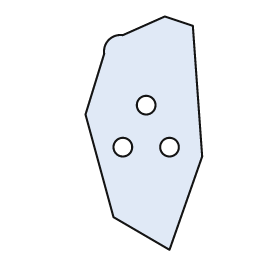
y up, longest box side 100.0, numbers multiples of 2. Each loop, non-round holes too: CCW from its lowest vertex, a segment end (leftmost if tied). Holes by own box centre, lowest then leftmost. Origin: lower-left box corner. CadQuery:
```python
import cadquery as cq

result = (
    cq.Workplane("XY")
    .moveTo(36.0, 0.0)
    .lineTo(50.0, 40.0)
    .lineTo(46.0, 96.0)
    .lineTo(34.0, 100.0)
    .lineTo(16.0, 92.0)
    .threePointArc((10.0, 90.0), (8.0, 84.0))
    .lineTo(0.0, 58.0)
    .lineTo(12.0, 14.0)
    .close()
    .moveTo(16.0, 44.0)
    .circle(4.0)
    .moveTo(36.0, 44.0)
    .circle(4.0)
    .moveTo(26.0, 62.0)
    .circle(4.0)
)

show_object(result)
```